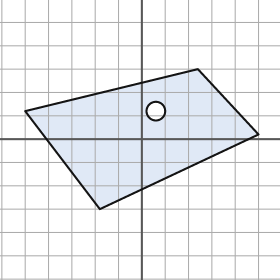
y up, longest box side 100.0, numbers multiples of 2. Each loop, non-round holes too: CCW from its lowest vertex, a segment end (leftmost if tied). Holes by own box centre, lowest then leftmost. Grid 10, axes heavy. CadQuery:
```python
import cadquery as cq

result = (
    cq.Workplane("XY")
    .moveTo(-18.0, -30.0)
    .lineTo(50.0, 2.0)
    .lineTo(24.0, 30.0)
    .lineTo(-50.0, 12.0)
    .close()
    .moveTo(6.0, 12.0)
    .circle(4.0)
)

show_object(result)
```